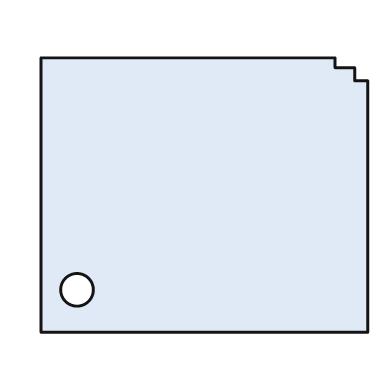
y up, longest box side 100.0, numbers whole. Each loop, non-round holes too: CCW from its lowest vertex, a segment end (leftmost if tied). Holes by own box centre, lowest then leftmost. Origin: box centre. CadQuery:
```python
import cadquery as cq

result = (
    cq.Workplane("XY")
    .moveTo(-50.0, -42.0)
    .lineTo(50.0, -42.0)
    .lineTo(50.0, 35.0)
    .lineTo(46.0, 35.0)
    .lineTo(46.0, 39.0)
    .lineTo(40.0, 39.0)
    .lineTo(40.0, 42.0)
    .lineTo(-50.0, 42.0)
    .close()
    .moveTo(-39.0, -29.0)
    .circle(5.0)
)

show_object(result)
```